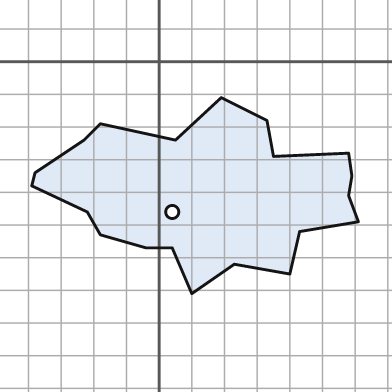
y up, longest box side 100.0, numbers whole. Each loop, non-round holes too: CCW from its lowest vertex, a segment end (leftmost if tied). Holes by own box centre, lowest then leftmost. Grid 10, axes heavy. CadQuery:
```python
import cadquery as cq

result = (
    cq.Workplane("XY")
    .moveTo(10.0, -71.0)
    .lineTo(23.0, -62.0)
    .lineTo(40.0, -65.0)
    .lineTo(43.0, -52.0)
    .lineTo(61.0, -49.0)
    .lineTo(58.0, -41.0)
    .lineTo(59.0, -35.0)
    .lineTo(58.0, -28.0)
    .lineTo(35.0, -29.0)
    .lineTo(33.0, -18.0)
    .lineTo(19.0, -11.0)
    .lineTo(5.0, -24.0)
    .lineTo(-18.0, -19.0)
    .lineTo(-23.0, -24.0)
    .lineTo(-38.0, -34.0)
    .lineTo(-39.0, -38.0)
    .lineTo(-22.0, -46.0)
    .lineTo(-18.0, -53.0)
    .lineTo(-4.0, -57.0)
    .lineTo(4.0, -57.0)
    .close()
    .moveTo(4.0, -46.0)
    .circle(2.0)
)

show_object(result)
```